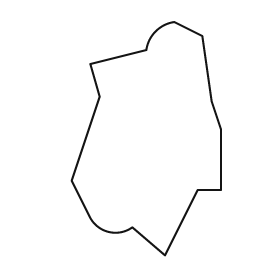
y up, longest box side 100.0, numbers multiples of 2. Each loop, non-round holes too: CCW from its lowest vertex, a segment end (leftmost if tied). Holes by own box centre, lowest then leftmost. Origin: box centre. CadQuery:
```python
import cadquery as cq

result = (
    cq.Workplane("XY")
    .moveTo(8.0, -50.0)
    .lineTo(22.0, -22.0)
    .lineTo(32.0, -22.0)
    .lineTo(32.0, 4.0)
    .lineTo(28.0, 16.0)
    .lineTo(24.0, 44.0)
    .lineTo(12.0, 50.0)
    .threePointArc((4.0, 46.0), (0.0, 38.0))
    .lineTo(-24.0, 32.0)
    .lineTo(-20.0, 18.0)
    .lineTo(-32.0, -18.0)
    .lineTo(-24.0, -34.0)
    .threePointArc((-16.0, -40.0), (-6.0, -38.0))
    .close()
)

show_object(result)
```